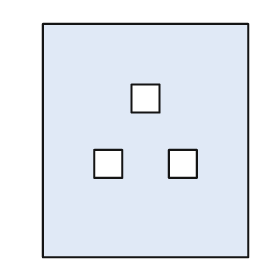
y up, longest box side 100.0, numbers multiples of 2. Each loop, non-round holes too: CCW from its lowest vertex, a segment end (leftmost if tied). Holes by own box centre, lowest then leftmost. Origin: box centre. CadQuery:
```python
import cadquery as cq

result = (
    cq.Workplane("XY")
    .moveTo(-44.0, -50.0)
    .lineTo(44.0, -50.0)
    .lineTo(44.0, 50.0)
    .lineTo(-44.0, 50.0)
    .close()
    .moveTo(-22.0, -16.0)
    .lineTo(-10.0, -16.0)
    .lineTo(-10.0, -4.0)
    .lineTo(-22.0, -4.0)
    .close()
    .moveTo(10.0, -16.0)
    .lineTo(22.0, -16.0)
    .lineTo(22.0, -4.0)
    .lineTo(10.0, -4.0)
    .close()
    .moveTo(-6.0, 12.0)
    .lineTo(6.0, 12.0)
    .lineTo(6.0, 24.0)
    .lineTo(-6.0, 24.0)
    .close()
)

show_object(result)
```